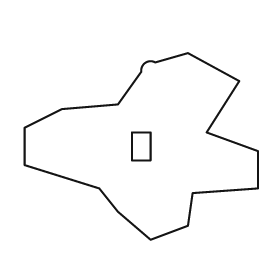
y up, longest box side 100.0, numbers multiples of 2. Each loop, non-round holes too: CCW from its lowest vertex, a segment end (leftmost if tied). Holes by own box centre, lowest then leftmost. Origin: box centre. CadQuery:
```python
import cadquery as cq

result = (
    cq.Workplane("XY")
    .moveTo(4.0, -40.0)
    .lineTo(20.0, -34.0)
    .lineTo(22.0, -20.0)
    .lineTo(50.0, -18.0)
    .lineTo(50.0, -2.0)
    .lineTo(28.0, 6.0)
    .lineTo(42.0, 28.0)
    .lineTo(20.0, 40.0)
    .lineTo(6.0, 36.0)
    .threePointArc((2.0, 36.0), (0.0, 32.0))
    .lineTo(-10.0, 18.0)
    .lineTo(-34.0, 16.0)
    .lineTo(-50.0, 8.0)
    .lineTo(-50.0, -8.0)
    .lineTo(-18.0, -18.0)
    .lineTo(-10.0, -28.0)
    .close()
    .moveTo(-4.0, -6.0)
    .lineTo(4.0, -6.0)
    .lineTo(4.0, 6.0)
    .lineTo(-4.0, 6.0)
    .close()
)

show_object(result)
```